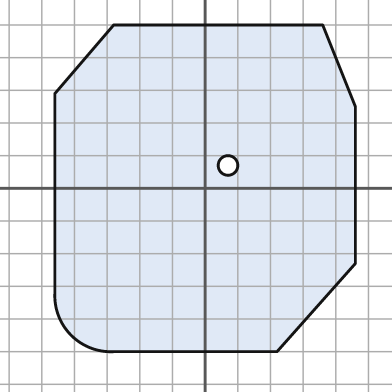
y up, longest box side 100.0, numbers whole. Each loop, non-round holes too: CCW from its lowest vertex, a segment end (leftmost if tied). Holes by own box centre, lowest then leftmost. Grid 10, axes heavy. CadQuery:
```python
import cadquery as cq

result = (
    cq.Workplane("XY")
    .moveTo(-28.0, -50.0)
    .lineTo(22.0, -50.0)
    .lineTo(46.0, -23.0)
    .lineTo(46.0, 25.0)
    .lineTo(36.0, 50.0)
    .lineTo(-28.0, 50.0)
    .lineTo(-46.0, 29.0)
    .lineTo(-46.0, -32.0)
    .threePointArc((-41.0, -45.0), (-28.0, -50.0))
    .close()
    .moveTo(7.0, 7.0)
    .circle(3.0)
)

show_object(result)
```